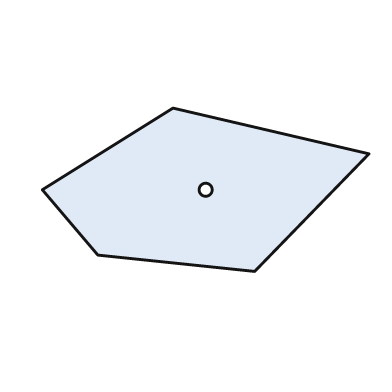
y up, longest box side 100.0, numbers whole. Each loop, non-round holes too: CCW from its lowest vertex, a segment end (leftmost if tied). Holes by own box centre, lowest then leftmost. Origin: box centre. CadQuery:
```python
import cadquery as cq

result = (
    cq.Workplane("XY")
    .moveTo(15.0, -25.0)
    .lineTo(50.0, 11.0)
    .lineTo(-10.0, 25.0)
    .lineTo(-50.0, 0.0)
    .lineTo(-33.0, -20.0)
    .close()
    .moveTo(0.0, 0.0)
    .circle(2.0)
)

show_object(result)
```